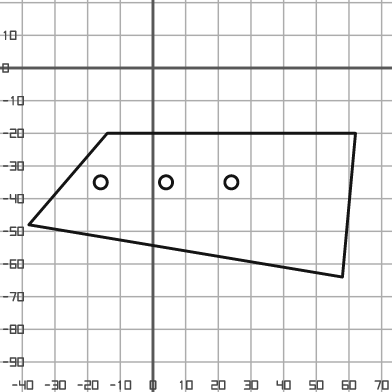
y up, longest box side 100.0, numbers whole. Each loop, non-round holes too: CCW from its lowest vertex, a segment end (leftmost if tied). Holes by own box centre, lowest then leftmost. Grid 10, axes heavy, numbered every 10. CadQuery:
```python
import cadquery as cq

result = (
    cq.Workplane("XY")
    .moveTo(58.0, -64.0)
    .lineTo(62.0, -20.0)
    .lineTo(-14.0, -20.0)
    .lineTo(-38.0, -48.0)
    .close()
    .moveTo(-16.0, -35.0)
    .circle(2.0)
    .moveTo(4.0, -35.0)
    .circle(2.0)
    .moveTo(24.0, -35.0)
    .circle(2.0)
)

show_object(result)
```